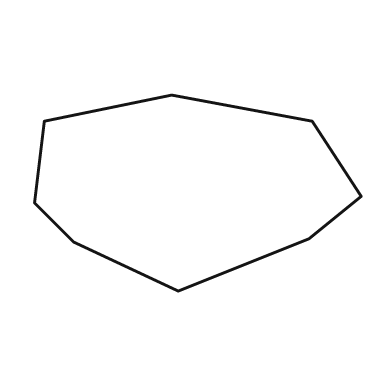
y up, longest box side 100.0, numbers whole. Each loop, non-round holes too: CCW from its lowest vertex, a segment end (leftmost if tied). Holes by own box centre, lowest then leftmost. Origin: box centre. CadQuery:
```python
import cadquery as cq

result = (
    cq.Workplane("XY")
    .moveTo(-6.0, -30.0)
    .lineTo(34.0, -14.0)
    .lineTo(50.0, -1.0)
    .lineTo(35.0, 22.0)
    .lineTo(-8.0, 30.0)
    .lineTo(-47.0, 22.0)
    .lineTo(-50.0, -3.0)
    .lineTo(-38.0, -15.0)
    .close()
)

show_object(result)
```